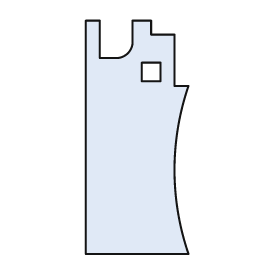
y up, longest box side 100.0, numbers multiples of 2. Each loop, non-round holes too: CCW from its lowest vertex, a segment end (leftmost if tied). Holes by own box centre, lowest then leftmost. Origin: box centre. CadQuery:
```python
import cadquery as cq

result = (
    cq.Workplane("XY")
    .moveTo(-22.0, -50.0)
    .lineTo(22.0, -50.0)
    .threePointArc((16.0, -14.0), (22.0, 22.0))
    .lineTo(16.0, 22.0)
    .lineTo(16.0, 44.0)
    .lineTo(6.0, 44.0)
    .lineTo(6.0, 50.0)
    .lineTo(-2.0, 50.0)
    .lineTo(-2.0, 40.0)
    .threePointArc((-4.0, 36.0), (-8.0, 34.0))
    .lineTo(-16.0, 34.0)
    .lineTo(-16.0, 50.0)
    .lineTo(-22.0, 50.0)
    .close()
    .moveTo(2.0, 24.0)
    .lineTo(10.0, 24.0)
    .lineTo(10.0, 32.0)
    .lineTo(2.0, 32.0)
    .close()
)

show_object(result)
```